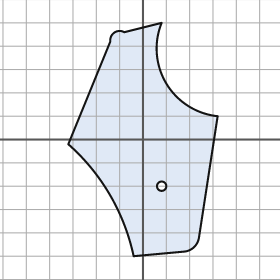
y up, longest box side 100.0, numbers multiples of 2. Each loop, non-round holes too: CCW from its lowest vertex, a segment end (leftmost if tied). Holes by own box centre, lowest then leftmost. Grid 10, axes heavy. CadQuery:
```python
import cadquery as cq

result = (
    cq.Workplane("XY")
    .moveTo(-4.0, -50.0)
    .lineTo(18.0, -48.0)
    .threePointArc((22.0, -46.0), (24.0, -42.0))
    .lineTo(32.0, 10.0)
    .threePointArc((10.0, 24.0), (8.0, 50.0))
    .lineTo(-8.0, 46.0)
    .threePointArc((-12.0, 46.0), (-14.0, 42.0))
    .lineTo(-32.0, -2.0)
    .threePointArc((-14.0, -24.0), (-4.0, -50.0))
    .close()
    .moveTo(8.0, -20.0)
    .circle(2.0)
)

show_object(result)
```